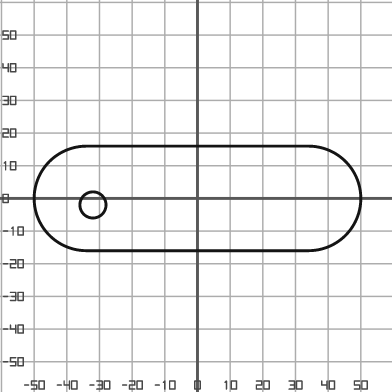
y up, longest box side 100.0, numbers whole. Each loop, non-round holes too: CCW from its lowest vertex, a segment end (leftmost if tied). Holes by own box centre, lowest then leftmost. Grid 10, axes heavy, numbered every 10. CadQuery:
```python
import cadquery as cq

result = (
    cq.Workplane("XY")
    .moveTo(-34.0, -16.0)
    .lineTo(34.0, -16.0)
    .threePointArc((50.0, 0.0), (34.0, 16.0))
    .lineTo(-34.0, 16.0)
    .threePointArc((-50.0, 0.0), (-34.0, -16.0))
    .close()
    .moveTo(-32.0, -2.0)
    .circle(4.0)
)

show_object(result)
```